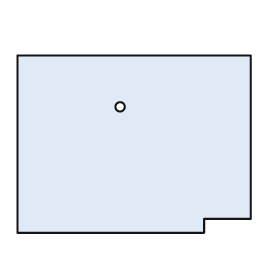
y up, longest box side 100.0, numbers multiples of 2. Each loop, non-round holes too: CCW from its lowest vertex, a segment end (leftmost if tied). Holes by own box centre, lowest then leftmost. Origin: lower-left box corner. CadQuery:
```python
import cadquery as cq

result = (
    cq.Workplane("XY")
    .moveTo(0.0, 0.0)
    .lineTo(80.0, 0.0)
    .lineTo(80.0, 6.0)
    .lineTo(100.0, 6.0)
    .lineTo(100.0, 76.0)
    .lineTo(0.0, 76.0)
    .close()
    .moveTo(44.0, 54.0)
    .circle(2.0)
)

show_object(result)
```